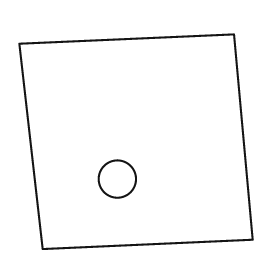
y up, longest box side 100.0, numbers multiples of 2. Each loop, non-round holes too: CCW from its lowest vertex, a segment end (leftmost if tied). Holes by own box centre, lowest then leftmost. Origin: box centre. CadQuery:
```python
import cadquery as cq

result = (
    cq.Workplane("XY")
    .moveTo(-40.0, -46.0)
    .lineTo(50.0, -42.0)
    .lineTo(42.0, 46.0)
    .lineTo(-50.0, 42.0)
    .close()
    .moveTo(-8.0, -16.0)
    .circle(8.0)
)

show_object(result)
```